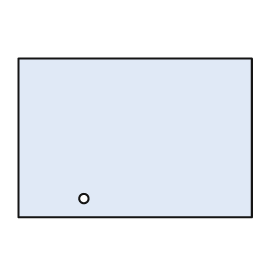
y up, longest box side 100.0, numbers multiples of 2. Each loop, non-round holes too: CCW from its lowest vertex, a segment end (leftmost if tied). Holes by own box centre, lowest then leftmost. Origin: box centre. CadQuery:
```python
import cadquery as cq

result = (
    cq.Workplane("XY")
    .moveTo(-50.0, -34.0)
    .lineTo(50.0, -34.0)
    .lineTo(50.0, 34.0)
    .lineTo(-50.0, 34.0)
    .close()
    .moveTo(-22.0, -26.0)
    .circle(2.0)
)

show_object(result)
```